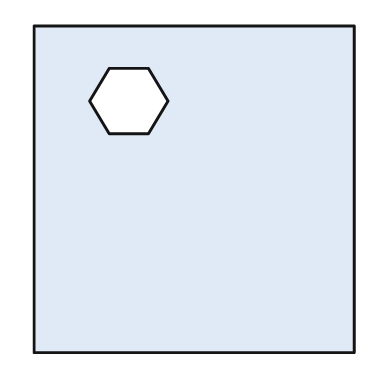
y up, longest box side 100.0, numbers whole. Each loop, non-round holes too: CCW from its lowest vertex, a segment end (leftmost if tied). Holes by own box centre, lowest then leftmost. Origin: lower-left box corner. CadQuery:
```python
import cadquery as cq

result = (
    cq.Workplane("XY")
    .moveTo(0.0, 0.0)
    .lineTo(98.0, 0.0)
    .lineTo(98.0, 100.0)
    .lineTo(0.0, 100.0)
    .close()
    .moveTo(23.0, 67.0)
    .lineTo(35.0, 67.0)
    .lineTo(41.0, 77.0)
    .lineTo(35.0, 87.0)
    .lineTo(23.0, 87.0)
    .lineTo(17.0, 77.0)
    .close()
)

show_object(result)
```